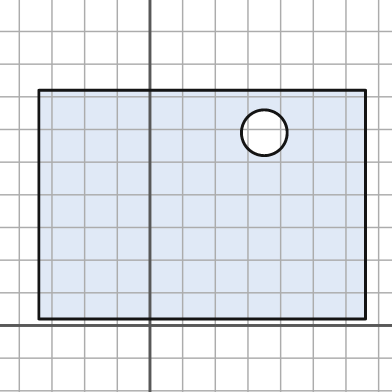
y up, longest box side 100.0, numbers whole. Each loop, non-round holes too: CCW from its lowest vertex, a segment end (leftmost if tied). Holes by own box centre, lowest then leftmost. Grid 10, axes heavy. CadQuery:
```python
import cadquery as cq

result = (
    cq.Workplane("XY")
    .moveTo(-34.0, 2.0)
    .lineTo(66.0, 2.0)
    .lineTo(66.0, 72.0)
    .lineTo(-34.0, 72.0)
    .close()
    .moveTo(35.0, 59.0)
    .circle(7.0)
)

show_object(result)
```